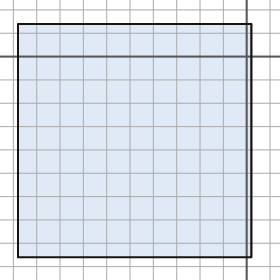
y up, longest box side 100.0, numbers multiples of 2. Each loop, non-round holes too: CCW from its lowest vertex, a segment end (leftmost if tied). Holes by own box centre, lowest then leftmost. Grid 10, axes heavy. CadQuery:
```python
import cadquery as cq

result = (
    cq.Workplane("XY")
    .moveTo(-98.0, -86.0)
    .lineTo(2.0, -86.0)
    .lineTo(2.0, 14.0)
    .lineTo(-98.0, 14.0)
    .close()
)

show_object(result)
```